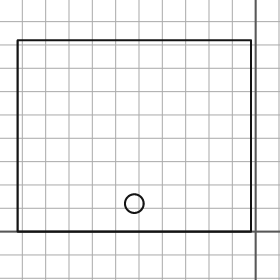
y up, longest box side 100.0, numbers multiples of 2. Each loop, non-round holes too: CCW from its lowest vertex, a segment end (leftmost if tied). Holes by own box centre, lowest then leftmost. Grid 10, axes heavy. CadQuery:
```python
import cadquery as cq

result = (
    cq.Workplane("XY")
    .moveTo(-102.0, 0.0)
    .lineTo(-2.0, 0.0)
    .lineTo(-2.0, 82.0)
    .lineTo(-102.0, 82.0)
    .close()
    .moveTo(-52.0, 12.0)
    .circle(4.0)
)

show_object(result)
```